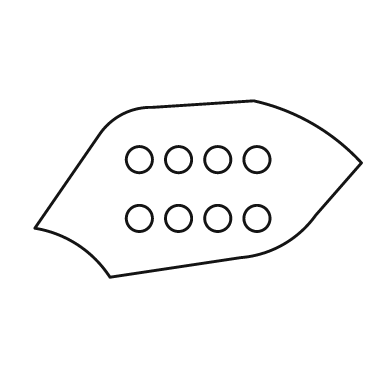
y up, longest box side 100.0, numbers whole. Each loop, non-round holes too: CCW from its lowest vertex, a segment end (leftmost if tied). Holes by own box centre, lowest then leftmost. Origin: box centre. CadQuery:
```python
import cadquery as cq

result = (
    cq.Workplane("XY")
    .moveTo(-27.0, -27.0)
    .lineTo(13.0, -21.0)
    .threePointArc((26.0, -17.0), (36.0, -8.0))
    .lineTo(50.0, 8.0)
    .threePointArc((35.0, 20.0), (17.0, 27.0))
    .lineTo(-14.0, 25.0)
    .threePointArc((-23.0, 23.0), (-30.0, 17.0))
    .lineTo(-50.0, -12.0)
    .threePointArc((-37.0, -17.0), (-27.0, -27.0))
    .close()
    .moveTo(-18.0, -9.0)
    .circle(4.0)
    .moveTo(-6.0, -9.0)
    .circle(4.0)
    .moveTo(6.0, -9.0)
    .circle(4.0)
    .moveTo(18.0, -9.0)
    .circle(4.0)
    .moveTo(-18.0, 9.0)
    .circle(4.0)
    .moveTo(-6.0, 9.0)
    .circle(4.0)
    .moveTo(6.0, 9.0)
    .circle(4.0)
    .moveTo(18.0, 9.0)
    .circle(4.0)
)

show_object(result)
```